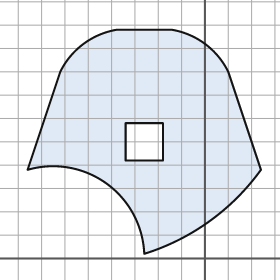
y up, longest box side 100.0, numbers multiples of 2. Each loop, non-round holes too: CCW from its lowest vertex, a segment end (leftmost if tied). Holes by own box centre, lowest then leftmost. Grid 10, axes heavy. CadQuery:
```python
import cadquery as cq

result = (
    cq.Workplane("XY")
    .moveTo(-26.0, 2.0)
    .threePointArc((2.0, 16.0), (24.0, 38.0))
    .lineTo(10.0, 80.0)
    .threePointArc((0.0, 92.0), (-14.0, 98.0))
    .lineTo(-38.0, 98.0)
    .threePointArc((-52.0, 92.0), (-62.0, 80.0))
    .lineTo(-76.0, 38.0)
    .threePointArc((-42.0, 32.0), (-26.0, 2.0))
    .close()
    .moveTo(-34.0, 42.0)
    .lineTo(-18.0, 42.0)
    .lineTo(-18.0, 58.0)
    .lineTo(-34.0, 58.0)
    .close()
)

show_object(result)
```